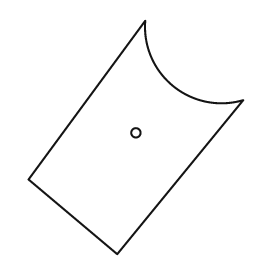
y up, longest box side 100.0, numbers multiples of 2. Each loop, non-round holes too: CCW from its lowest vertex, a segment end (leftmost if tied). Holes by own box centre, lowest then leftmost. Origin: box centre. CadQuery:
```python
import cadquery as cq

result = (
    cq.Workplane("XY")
    .moveTo(-8.0, -50.0)
    .lineTo(46.0, 16.0)
    .threePointArc((16.0, 22.0), (4.0, 50.0))
    .lineTo(-46.0, -18.0)
    .close()
    .moveTo(0.0, 2.0)
    .circle(2.0)
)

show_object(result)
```